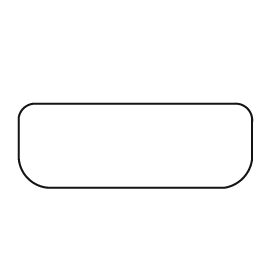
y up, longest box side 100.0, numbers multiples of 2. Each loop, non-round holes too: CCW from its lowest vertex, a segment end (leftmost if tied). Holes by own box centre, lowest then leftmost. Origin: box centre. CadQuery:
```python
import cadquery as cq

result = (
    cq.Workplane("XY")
    .moveTo(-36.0, -18.0)
    .lineTo(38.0, -18.0)
    .threePointArc((46.0, -14.0), (50.0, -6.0))
    .lineTo(50.0, 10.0)
    .threePointArc((48.0, 16.0), (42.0, 18.0))
    .lineTo(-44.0, 18.0)
    .threePointArc((-48.0, 16.0), (-50.0, 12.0))
    .lineTo(-50.0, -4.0)
    .threePointArc((-46.0, -14.0), (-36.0, -18.0))
    .close()
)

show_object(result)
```